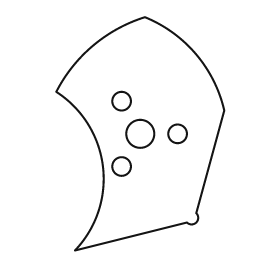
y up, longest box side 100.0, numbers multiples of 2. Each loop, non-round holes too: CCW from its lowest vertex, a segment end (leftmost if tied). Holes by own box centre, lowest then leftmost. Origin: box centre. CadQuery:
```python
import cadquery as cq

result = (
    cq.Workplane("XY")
    .moveTo(-28.0, -50.0)
    .lineTo(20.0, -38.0)
    .threePointArc((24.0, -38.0), (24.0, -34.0))
    .lineTo(36.0, 10.0)
    .threePointArc((24.0, 34.0), (2.0, 50.0))
    .threePointArc((-20.0, 38.0), (-36.0, 18.0))
    .threePointArc((-16.0, -14.0), (-28.0, -50.0))
    .close()
    .moveTo(-8.0, -14.0)
    .circle(4.0)
    .moveTo(0.0, 0.0)
    .circle(6.0)
    .moveTo(16.0, 0.0)
    .circle(4.0)
    .moveTo(-8.0, 14.0)
    .circle(4.0)
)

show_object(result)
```